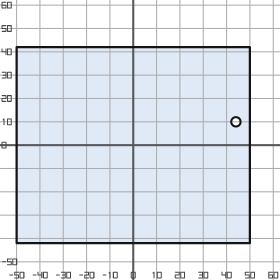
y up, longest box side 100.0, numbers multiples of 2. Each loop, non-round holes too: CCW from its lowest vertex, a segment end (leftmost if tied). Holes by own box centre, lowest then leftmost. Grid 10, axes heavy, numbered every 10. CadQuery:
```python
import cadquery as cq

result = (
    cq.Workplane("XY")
    .moveTo(-50.0, -42.0)
    .lineTo(50.0, -42.0)
    .lineTo(50.0, 42.0)
    .lineTo(-50.0, 42.0)
    .close()
    .moveTo(44.0, 10.0)
    .circle(2.0)
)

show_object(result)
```